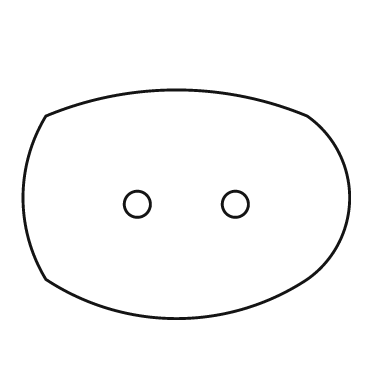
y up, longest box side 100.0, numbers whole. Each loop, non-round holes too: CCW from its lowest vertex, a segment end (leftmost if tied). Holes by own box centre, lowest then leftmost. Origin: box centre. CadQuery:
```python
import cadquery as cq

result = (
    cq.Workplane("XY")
    .moveTo(-43.0, -23.0)
    .threePointArc((-3.0, -35.0), (37.0, -23.0))
    .threePointArc((50.0, 2.0), (37.0, 27.0))
    .threePointArc((-3.0, 35.0), (-43.0, 27.0))
    .threePointArc((-50.0, 2.0), (-43.0, -23.0))
    .close()
    .moveTo(-15.0, 0.0)
    .circle(4.0)
    .moveTo(15.0, 0.0)
    .circle(4.0)
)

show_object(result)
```